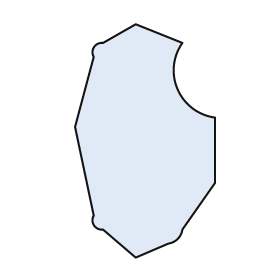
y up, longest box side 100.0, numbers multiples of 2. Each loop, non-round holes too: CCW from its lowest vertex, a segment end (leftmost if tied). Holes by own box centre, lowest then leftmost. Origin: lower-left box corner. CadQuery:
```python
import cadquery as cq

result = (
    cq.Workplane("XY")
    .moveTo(26.0, 0.0)
    .lineTo(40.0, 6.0)
    .threePointArc((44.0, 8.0), (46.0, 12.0))
    .lineTo(60.0, 32.0)
    .lineTo(60.0, 60.0)
    .threePointArc((44.0, 72.0), (46.0, 92.0))
    .lineTo(26.0, 100.0)
    .lineTo(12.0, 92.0)
    .threePointArc((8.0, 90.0), (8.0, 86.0))
    .lineTo(0.0, 56.0)
    .lineTo(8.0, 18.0)
    .threePointArc((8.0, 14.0), (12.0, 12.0))
    .close()
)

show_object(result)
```